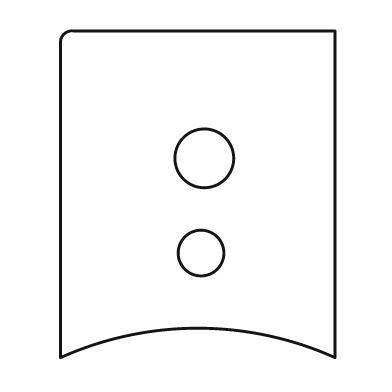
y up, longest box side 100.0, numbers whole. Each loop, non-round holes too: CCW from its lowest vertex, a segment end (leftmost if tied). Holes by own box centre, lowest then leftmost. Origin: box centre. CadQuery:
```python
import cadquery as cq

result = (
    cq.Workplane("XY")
    .moveTo(-42.0, -50.0)
    .threePointArc((0.0, -41.0), (42.0, -50.0))
    .lineTo(42.0, 50.0)
    .lineTo(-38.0, 50.0)
    .threePointArc((-41.0, 49.0), (-42.0, 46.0))
    .close()
    .moveTo(1.0, -18.0)
    .circle(7.0)
    .moveTo(2.0, 11.0)
    .circle(9.0)
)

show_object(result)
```